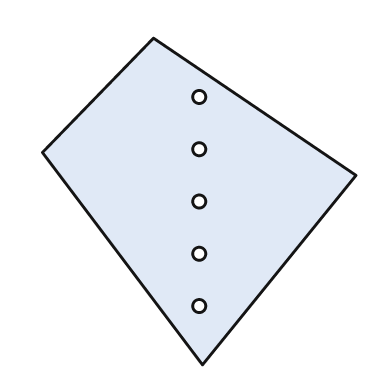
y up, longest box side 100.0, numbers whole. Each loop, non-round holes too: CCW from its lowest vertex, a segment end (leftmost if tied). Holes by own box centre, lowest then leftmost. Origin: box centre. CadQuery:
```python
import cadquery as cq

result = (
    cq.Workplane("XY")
    .moveTo(1.0, -50.0)
    .lineTo(48.0, 8.0)
    .lineTo(-14.0, 50.0)
    .lineTo(-48.0, 15.0)
    .close()
    .moveTo(0.0, -32.0)
    .circle(2.0)
    .moveTo(0.0, -16.0)
    .circle(2.0)
    .moveTo(0.0, 0.0)
    .circle(2.0)
    .moveTo(0.0, 16.0)
    .circle(2.0)
    .moveTo(0.0, 32.0)
    .circle(2.0)
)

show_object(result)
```